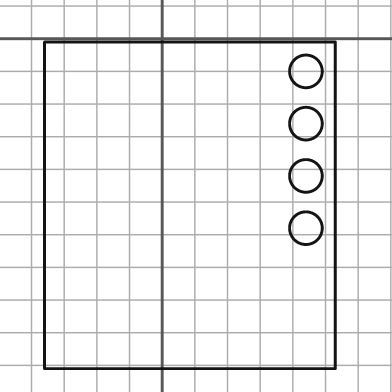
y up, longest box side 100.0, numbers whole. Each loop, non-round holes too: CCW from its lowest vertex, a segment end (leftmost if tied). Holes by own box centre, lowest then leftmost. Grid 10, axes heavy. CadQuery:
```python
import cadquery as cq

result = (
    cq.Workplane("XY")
    .moveTo(-36.0, -101.0)
    .lineTo(53.0, -101.0)
    .lineTo(53.0, -1.0)
    .lineTo(-36.0, -1.0)
    .close()
    .moveTo(44.0, -58.0)
    .circle(5.0)
    .moveTo(44.0, -42.0)
    .circle(5.0)
    .moveTo(44.0, -26.0)
    .circle(5.0)
    .moveTo(44.0, -10.0)
    .circle(5.0)
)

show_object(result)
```